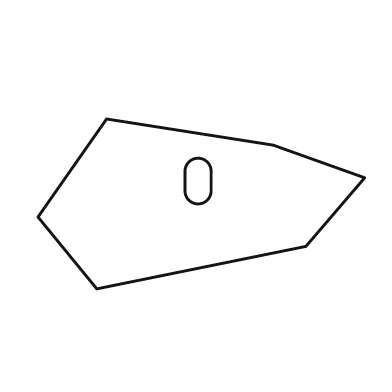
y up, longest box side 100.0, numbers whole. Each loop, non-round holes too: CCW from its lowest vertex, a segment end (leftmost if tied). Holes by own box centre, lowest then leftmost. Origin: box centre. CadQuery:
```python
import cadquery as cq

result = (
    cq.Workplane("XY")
    .moveTo(-32.0, -26.0)
    .lineTo(32.0, -13.0)
    .lineTo(50.0, 8.0)
    .lineTo(22.0, 18.0)
    .lineTo(-29.0, 26.0)
    .lineTo(-50.0, -4.0)
    .close()
    .moveTo(-5.0, 4.0)
    .threePointArc((-1.0, 0.0), (3.0, 4.0))
    .lineTo(3.0, 10.0)
    .threePointArc((-1.0, 14.0), (-5.0, 10.0))
    .close()
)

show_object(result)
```